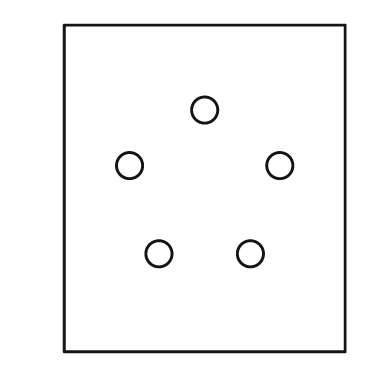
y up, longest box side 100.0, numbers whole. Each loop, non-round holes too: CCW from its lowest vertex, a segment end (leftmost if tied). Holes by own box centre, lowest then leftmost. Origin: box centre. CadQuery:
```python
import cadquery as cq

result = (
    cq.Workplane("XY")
    .moveTo(-43.0, -50.0)
    .lineTo(43.0, -50.0)
    .lineTo(43.0, 50.0)
    .lineTo(-43.0, 50.0)
    .close()
    .moveTo(-14.0, -20.0)
    .circle(4.0)
    .moveTo(14.0, -20.0)
    .circle(4.0)
    .moveTo(-23.0, 7.0)
    .circle(4.0)
    .moveTo(23.0, 7.0)
    .circle(4.0)
    .moveTo(0.0, 24.0)
    .circle(4.0)
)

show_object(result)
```